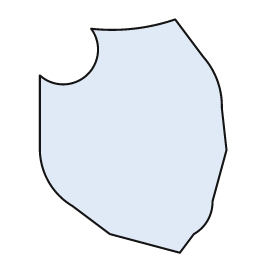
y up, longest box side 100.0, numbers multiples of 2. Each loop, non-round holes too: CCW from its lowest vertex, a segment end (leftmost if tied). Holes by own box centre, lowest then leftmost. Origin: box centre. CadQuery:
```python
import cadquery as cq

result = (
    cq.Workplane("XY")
    .moveTo(20.0, -50.0)
    .lineTo(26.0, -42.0)
    .threePointArc((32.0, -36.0), (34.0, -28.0))
    .lineTo(40.0, -6.0)
    .lineTo(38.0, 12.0)
    .threePointArc((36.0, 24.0), (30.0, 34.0))
    .lineTo(18.0, 50.0)
    .threePointArc((0.0, 46.0), (-18.0, 46.0))
    .threePointArc((-20.0, 26.0), (-40.0, 26.0))
    .lineTo(-40.0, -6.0)
    .threePointArc((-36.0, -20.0), (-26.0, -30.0))
    .lineTo(-10.0, -42.0)
    .close()
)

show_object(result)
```